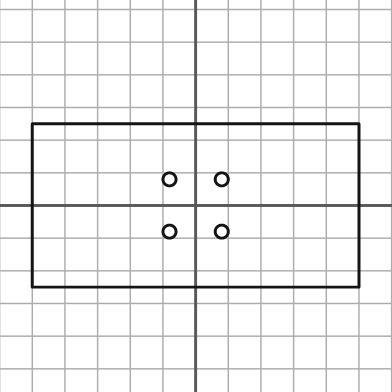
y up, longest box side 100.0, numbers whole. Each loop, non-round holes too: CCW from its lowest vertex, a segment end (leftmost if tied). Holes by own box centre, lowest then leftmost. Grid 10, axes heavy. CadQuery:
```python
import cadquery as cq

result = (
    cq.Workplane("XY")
    .moveTo(-50.0, -25.0)
    .lineTo(50.0, -25.0)
    .lineTo(50.0, 25.0)
    .lineTo(-50.0, 25.0)
    .close()
    .moveTo(-8.0, -8.0)
    .circle(2.0)
    .moveTo(8.0, -8.0)
    .circle(2.0)
    .moveTo(-8.0, 8.0)
    .circle(2.0)
    .moveTo(8.0, 8.0)
    .circle(2.0)
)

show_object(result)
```